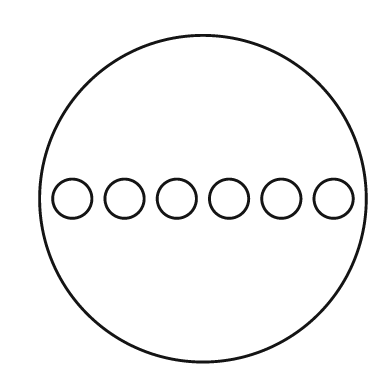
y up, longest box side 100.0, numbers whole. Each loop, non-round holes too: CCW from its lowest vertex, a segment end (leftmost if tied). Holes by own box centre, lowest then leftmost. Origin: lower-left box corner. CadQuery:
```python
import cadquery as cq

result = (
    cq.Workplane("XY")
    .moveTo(50.0, 50.0)
    .circle(50.0)
    .moveTo(10.0, 50.0)
    .circle(6.0)
    .moveTo(26.0, 50.0)
    .circle(6.0)
    .moveTo(42.0, 50.0)
    .circle(6.0)
    .moveTo(58.0, 50.0)
    .circle(6.0)
    .moveTo(74.0, 50.0)
    .circle(6.0)
    .moveTo(90.0, 50.0)
    .circle(6.0)
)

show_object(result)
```